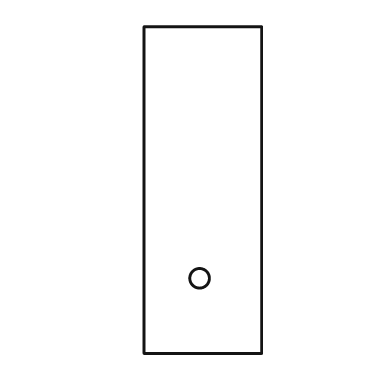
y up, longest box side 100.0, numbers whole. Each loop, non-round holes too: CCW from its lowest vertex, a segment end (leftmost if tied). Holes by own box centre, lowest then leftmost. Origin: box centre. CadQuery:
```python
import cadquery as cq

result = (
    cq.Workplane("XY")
    .moveTo(-18.0, -50.0)
    .lineTo(18.0, -50.0)
    .lineTo(18.0, 50.0)
    .lineTo(-18.0, 50.0)
    .close()
    .moveTo(-1.0, -27.0)
    .circle(3.0)
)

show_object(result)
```